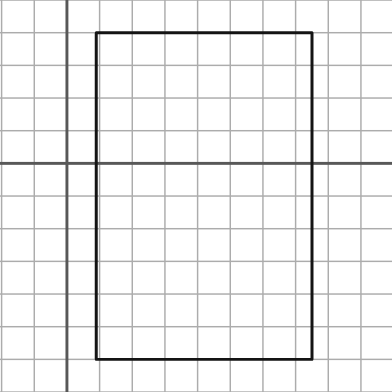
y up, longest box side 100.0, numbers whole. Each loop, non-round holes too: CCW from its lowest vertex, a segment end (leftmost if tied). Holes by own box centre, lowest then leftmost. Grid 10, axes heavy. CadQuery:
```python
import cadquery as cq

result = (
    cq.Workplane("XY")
    .moveTo(9.0, -60.0)
    .lineTo(75.0, -60.0)
    .lineTo(75.0, 40.0)
    .lineTo(9.0, 40.0)
    .close()
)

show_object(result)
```